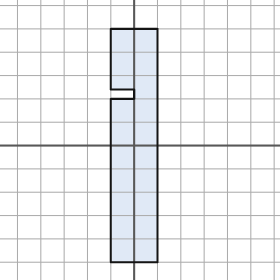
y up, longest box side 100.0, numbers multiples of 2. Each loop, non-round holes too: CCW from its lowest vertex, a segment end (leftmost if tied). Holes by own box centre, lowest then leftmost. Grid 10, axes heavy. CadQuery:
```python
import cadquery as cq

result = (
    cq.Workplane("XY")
    .moveTo(-10.0, -50.0)
    .lineTo(10.0, -50.0)
    .lineTo(10.0, 50.0)
    .lineTo(-10.0, 50.0)
    .lineTo(-10.0, 24.0)
    .lineTo(0.0, 24.0)
    .lineTo(0.0, 20.0)
    .lineTo(-10.0, 20.0)
    .close()
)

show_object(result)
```